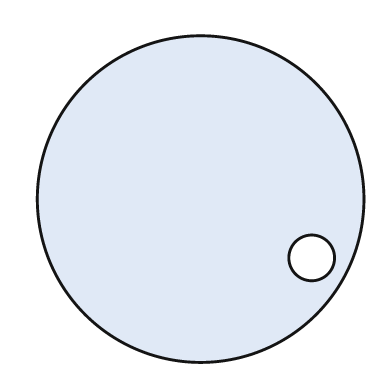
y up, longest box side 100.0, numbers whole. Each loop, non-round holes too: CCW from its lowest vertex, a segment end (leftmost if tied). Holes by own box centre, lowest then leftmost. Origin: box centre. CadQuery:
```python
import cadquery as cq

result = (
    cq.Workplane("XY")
    .moveTo(0.0, 0.0)
    .circle(50.0)
    .moveTo(34.0, -18.0)
    .circle(7.0)
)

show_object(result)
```